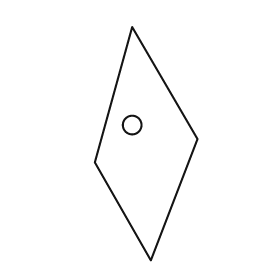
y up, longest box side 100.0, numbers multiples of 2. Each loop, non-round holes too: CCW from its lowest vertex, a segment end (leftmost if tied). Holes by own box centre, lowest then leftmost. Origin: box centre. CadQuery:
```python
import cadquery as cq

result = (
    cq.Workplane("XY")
    .moveTo(2.0, -50.0)
    .lineTo(22.0, 2.0)
    .lineTo(-6.0, 50.0)
    .lineTo(-22.0, -8.0)
    .close()
    .moveTo(-6.0, 8.0)
    .circle(4.0)
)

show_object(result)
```